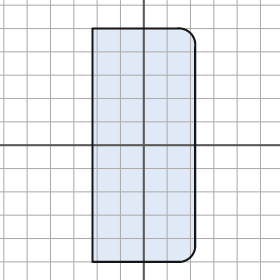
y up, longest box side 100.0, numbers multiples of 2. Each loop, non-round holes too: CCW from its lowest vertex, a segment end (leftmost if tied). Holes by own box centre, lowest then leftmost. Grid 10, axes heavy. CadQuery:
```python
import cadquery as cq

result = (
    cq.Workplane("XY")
    .moveTo(-22.0, -50.0)
    .lineTo(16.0, -50.0)
    .threePointArc((20.0, -48.0), (22.0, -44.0))
    .lineTo(22.0, 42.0)
    .threePointArc((20.0, 48.0), (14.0, 50.0))
    .lineTo(-22.0, 50.0)
    .close()
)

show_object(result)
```